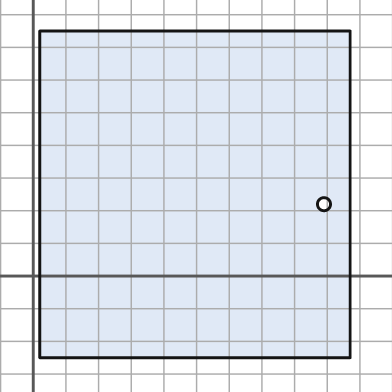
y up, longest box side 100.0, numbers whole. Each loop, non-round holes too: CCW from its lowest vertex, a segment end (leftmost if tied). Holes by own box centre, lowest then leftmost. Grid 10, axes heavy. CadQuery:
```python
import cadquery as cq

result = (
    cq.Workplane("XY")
    .moveTo(2.0, -25.0)
    .lineTo(97.0, -25.0)
    .lineTo(97.0, 75.0)
    .lineTo(2.0, 75.0)
    .close()
    .moveTo(89.0, 22.0)
    .circle(2.0)
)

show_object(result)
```